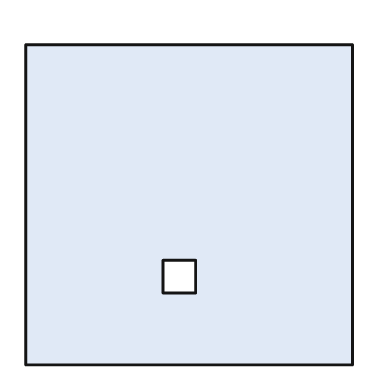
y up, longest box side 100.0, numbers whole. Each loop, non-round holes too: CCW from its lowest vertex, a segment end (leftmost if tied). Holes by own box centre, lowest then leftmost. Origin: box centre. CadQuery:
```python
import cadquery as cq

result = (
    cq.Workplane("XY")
    .moveTo(-50.0, -49.0)
    .lineTo(50.0, -49.0)
    .lineTo(50.0, 49.0)
    .lineTo(-50.0, 49.0)
    .close()
    .moveTo(-8.0, -27.0)
    .lineTo(2.0, -27.0)
    .lineTo(2.0, -17.0)
    .lineTo(-8.0, -17.0)
    .close()
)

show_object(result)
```